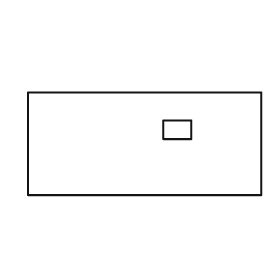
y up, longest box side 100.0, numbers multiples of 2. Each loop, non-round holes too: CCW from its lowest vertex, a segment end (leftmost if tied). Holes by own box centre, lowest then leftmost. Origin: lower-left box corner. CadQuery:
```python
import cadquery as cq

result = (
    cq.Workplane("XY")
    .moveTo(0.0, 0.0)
    .lineTo(100.0, 0.0)
    .lineTo(100.0, 44.0)
    .lineTo(0.0, 44.0)
    .close()
    .moveTo(58.0, 24.0)
    .lineTo(70.0, 24.0)
    .lineTo(70.0, 32.0)
    .lineTo(58.0, 32.0)
    .close()
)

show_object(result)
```